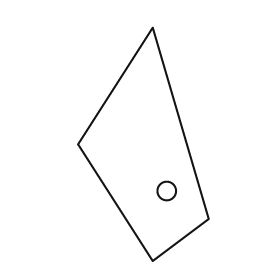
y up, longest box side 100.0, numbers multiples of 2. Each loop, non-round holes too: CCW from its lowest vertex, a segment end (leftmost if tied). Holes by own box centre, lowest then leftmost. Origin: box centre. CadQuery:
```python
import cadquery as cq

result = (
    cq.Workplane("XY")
    .moveTo(4.0, -50.0)
    .lineTo(28.0, -32.0)
    .lineTo(4.0, 50.0)
    .lineTo(-28.0, 0.0)
    .close()
    .moveTo(10.0, -20.0)
    .circle(4.0)
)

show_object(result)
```